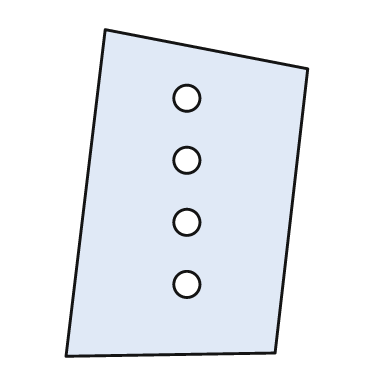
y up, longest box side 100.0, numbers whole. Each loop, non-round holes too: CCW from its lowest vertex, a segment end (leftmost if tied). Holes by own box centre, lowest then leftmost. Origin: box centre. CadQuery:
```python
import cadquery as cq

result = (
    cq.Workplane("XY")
    .moveTo(-37.0, -50.0)
    .lineTo(27.0, -49.0)
    .lineTo(37.0, 38.0)
    .lineTo(-25.0, 50.0)
    .close()
    .moveTo(0.0, -28.0)
    .circle(4.0)
    .moveTo(0.0, -9.0)
    .circle(4.0)
    .moveTo(0.0, 10.0)
    .circle(4.0)
    .moveTo(0.0, 29.0)
    .circle(4.0)
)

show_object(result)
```